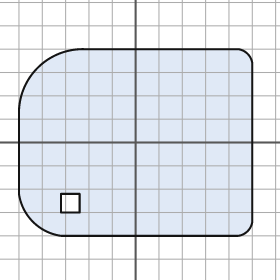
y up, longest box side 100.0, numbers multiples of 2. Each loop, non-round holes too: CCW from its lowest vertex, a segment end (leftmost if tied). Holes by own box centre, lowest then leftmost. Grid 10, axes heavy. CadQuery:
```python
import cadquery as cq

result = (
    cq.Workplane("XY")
    .moveTo(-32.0, -40.0)
    .lineTo(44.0, -40.0)
    .threePointArc((48.0, -38.0), (50.0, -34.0))
    .lineTo(50.0, 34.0)
    .threePointArc((48.0, 38.0), (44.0, 40.0))
    .lineTo(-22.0, 40.0)
    .threePointArc((-42.0, 32.0), (-50.0, 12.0))
    .lineTo(-50.0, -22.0)
    .threePointArc((-44.0, -34.0), (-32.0, -40.0))
    .close()
    .moveTo(-32.0, -30.0)
    .lineTo(-24.0, -30.0)
    .lineTo(-24.0, -22.0)
    .lineTo(-32.0, -22.0)
    .close()
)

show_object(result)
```